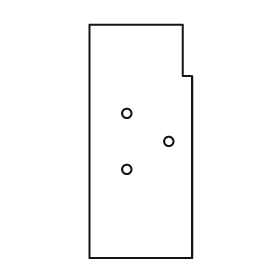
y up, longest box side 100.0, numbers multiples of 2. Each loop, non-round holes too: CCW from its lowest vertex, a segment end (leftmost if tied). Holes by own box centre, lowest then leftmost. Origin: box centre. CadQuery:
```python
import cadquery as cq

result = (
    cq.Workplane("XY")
    .moveTo(-22.0, -50.0)
    .lineTo(22.0, -50.0)
    .lineTo(22.0, 28.0)
    .lineTo(18.0, 28.0)
    .lineTo(18.0, 50.0)
    .lineTo(-22.0, 50.0)
    .close()
    .moveTo(-6.0, -12.0)
    .circle(2.0)
    .moveTo(12.0, 0.0)
    .circle(2.0)
    .moveTo(-6.0, 12.0)
    .circle(2.0)
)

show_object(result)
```